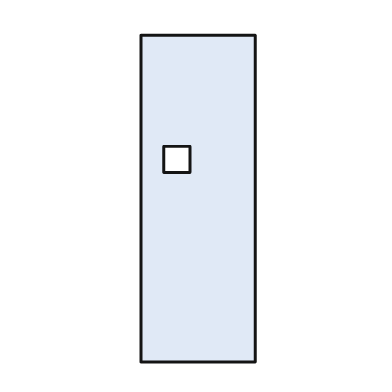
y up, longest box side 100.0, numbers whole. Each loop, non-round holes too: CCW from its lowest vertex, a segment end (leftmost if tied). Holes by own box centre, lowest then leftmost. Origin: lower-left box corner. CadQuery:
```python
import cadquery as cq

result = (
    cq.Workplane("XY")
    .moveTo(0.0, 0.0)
    .lineTo(35.0, 0.0)
    .lineTo(35.0, 100.0)
    .lineTo(0.0, 100.0)
    .close()
    .moveTo(7.0, 58.0)
    .lineTo(15.0, 58.0)
    .lineTo(15.0, 66.0)
    .lineTo(7.0, 66.0)
    .close()
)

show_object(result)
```